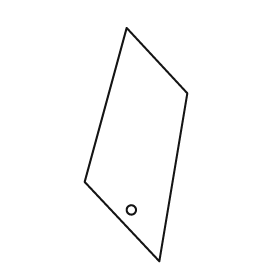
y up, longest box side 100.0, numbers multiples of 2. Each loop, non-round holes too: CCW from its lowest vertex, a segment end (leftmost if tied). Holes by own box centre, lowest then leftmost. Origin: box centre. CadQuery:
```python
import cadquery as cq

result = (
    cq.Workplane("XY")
    .moveTo(10.0, -50.0)
    .lineTo(22.0, 22.0)
    .lineTo(-4.0, 50.0)
    .lineTo(-22.0, -16.0)
    .close()
    .moveTo(-2.0, -28.0)
    .circle(2.0)
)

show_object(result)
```